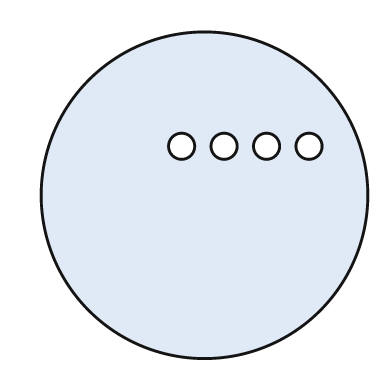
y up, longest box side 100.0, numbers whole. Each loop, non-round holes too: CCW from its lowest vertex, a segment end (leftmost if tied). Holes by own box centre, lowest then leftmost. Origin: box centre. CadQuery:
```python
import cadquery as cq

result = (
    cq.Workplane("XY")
    .moveTo(0.0, 0.0)
    .circle(50.0)
    .moveTo(-7.0, 15.0)
    .circle(4.0)
    .moveTo(6.0, 15.0)
    .circle(4.0)
    .moveTo(19.0, 15.0)
    .circle(4.0)
    .moveTo(32.0, 15.0)
    .circle(4.0)
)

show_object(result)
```